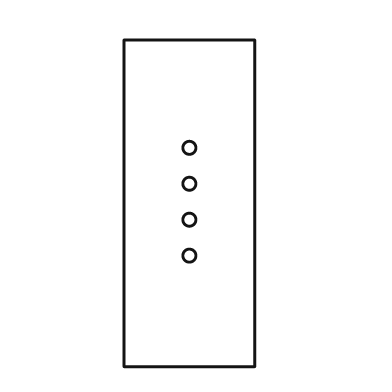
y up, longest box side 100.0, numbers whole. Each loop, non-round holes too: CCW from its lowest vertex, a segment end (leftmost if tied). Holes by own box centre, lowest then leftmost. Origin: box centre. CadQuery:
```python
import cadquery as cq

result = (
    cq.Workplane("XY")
    .moveTo(-20.0, -50.0)
    .lineTo(20.0, -50.0)
    .lineTo(20.0, 50.0)
    .lineTo(-20.0, 50.0)
    .close()
    .moveTo(0.0, -16.0)
    .circle(2.0)
    .moveTo(0.0, -5.0)
    .circle(2.0)
    .moveTo(0.0, 6.0)
    .circle(2.0)
    .moveTo(0.0, 17.0)
    .circle(2.0)
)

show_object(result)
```